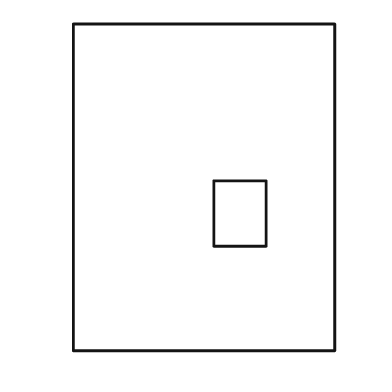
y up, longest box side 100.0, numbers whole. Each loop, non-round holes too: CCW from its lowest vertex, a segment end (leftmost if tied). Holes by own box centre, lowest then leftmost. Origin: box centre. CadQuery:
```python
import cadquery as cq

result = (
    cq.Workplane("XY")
    .moveTo(-40.0, -50.0)
    .lineTo(40.0, -50.0)
    .lineTo(40.0, 50.0)
    .lineTo(-40.0, 50.0)
    .close()
    .moveTo(3.0, -18.0)
    .lineTo(19.0, -18.0)
    .lineTo(19.0, 2.0)
    .lineTo(3.0, 2.0)
    .close()
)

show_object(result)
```